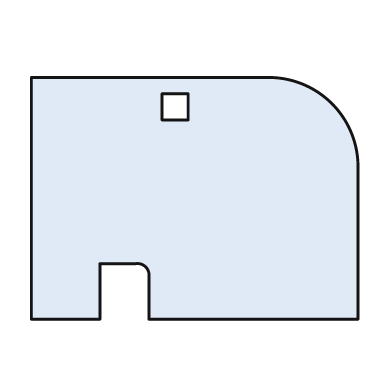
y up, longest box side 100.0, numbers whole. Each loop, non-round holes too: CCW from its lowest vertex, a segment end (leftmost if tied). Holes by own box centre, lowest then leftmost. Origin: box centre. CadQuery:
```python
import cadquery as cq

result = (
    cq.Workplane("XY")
    .moveTo(-50.0, -37.0)
    .lineTo(-29.0, -37.0)
    .lineTo(-29.0, -20.0)
    .lineTo(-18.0, -20.0)
    .threePointArc((-15.0, -21.0), (-14.0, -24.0))
    .lineTo(-14.0, -37.0)
    .lineTo(50.0, -37.0)
    .lineTo(50.0, 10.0)
    .threePointArc((42.0, 29.0), (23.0, 37.0))
    .lineTo(-50.0, 37.0)
    .close()
    .moveTo(-10.0, 24.0)
    .lineTo(-2.0, 24.0)
    .lineTo(-2.0, 32.0)
    .lineTo(-10.0, 32.0)
    .close()
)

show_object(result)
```